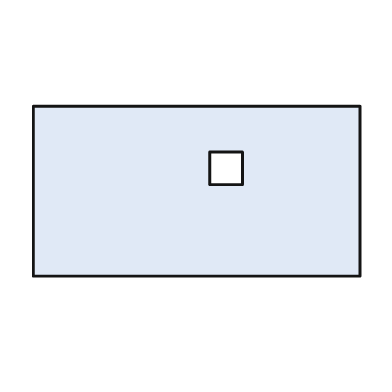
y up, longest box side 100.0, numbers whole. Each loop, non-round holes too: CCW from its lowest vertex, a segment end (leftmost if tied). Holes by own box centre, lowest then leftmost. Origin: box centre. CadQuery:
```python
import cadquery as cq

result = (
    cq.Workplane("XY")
    .moveTo(-50.0, -26.0)
    .lineTo(50.0, -26.0)
    .lineTo(50.0, 26.0)
    .lineTo(-50.0, 26.0)
    .close()
    .moveTo(4.0, 2.0)
    .lineTo(14.0, 2.0)
    .lineTo(14.0, 12.0)
    .lineTo(4.0, 12.0)
    .close()
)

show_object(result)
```